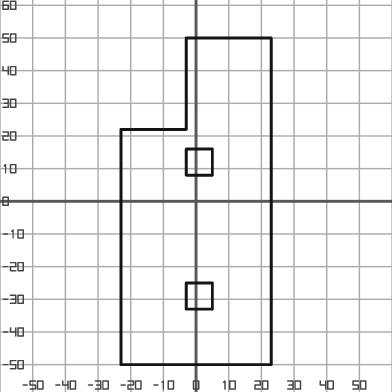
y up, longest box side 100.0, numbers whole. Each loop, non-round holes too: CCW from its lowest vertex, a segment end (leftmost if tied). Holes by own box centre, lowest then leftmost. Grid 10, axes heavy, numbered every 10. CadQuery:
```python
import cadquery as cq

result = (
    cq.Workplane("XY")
    .moveTo(-23.0, -50.0)
    .lineTo(23.0, -50.0)
    .lineTo(23.0, 50.0)
    .lineTo(-3.0, 50.0)
    .lineTo(-3.0, 22.0)
    .lineTo(-23.0, 22.0)
    .close()
    .moveTo(-3.0, -33.0)
    .lineTo(5.0, -33.0)
    .lineTo(5.0, -25.0)
    .lineTo(-3.0, -25.0)
    .close()
    .moveTo(-3.0, 8.0)
    .lineTo(5.0, 8.0)
    .lineTo(5.0, 16.0)
    .lineTo(-3.0, 16.0)
    .close()
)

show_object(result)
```